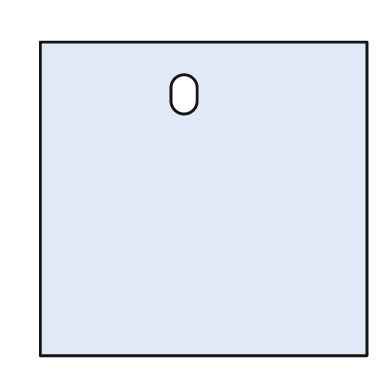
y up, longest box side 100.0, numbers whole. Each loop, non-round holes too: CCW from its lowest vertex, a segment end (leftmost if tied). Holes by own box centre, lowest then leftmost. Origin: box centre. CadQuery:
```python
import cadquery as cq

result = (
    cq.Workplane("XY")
    .moveTo(-50.0, -48.0)
    .lineTo(50.0, -48.0)
    .lineTo(50.0, 48.0)
    .lineTo(-50.0, 48.0)
    .close()
    .moveTo(-10.0, 30.0)
    .threePointArc((-6.0, 26.0), (-2.0, 30.0))
    .lineTo(-2.0, 34.0)
    .threePointArc((-6.0, 38.0), (-10.0, 34.0))
    .close()
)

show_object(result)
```